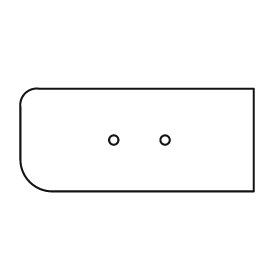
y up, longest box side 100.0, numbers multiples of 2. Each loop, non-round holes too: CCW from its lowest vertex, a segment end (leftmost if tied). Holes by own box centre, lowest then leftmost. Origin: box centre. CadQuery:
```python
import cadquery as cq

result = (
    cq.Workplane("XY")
    .moveTo(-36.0, -22.0)
    .lineTo(50.0, -22.0)
    .lineTo(50.0, 22.0)
    .lineTo(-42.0, 22.0)
    .threePointArc((-48.0, 20.0), (-50.0, 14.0))
    .lineTo(-50.0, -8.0)
    .threePointArc((-46.0, -18.0), (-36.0, -22.0))
    .close()
    .moveTo(-10.0, 0.0)
    .circle(2.0)
    .moveTo(12.0, 0.0)
    .circle(2.0)
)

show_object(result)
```